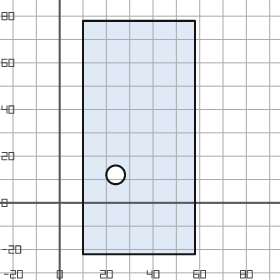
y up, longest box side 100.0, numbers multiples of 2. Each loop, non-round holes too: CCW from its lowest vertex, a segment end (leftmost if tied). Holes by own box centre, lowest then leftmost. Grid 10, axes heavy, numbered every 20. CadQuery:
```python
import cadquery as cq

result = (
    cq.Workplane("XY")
    .moveTo(10.0, -22.0)
    .lineTo(58.0, -22.0)
    .lineTo(58.0, 78.0)
    .lineTo(10.0, 78.0)
    .close()
    .moveTo(24.0, 12.0)
    .circle(4.0)
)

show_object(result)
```